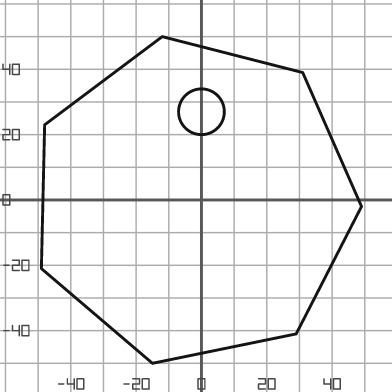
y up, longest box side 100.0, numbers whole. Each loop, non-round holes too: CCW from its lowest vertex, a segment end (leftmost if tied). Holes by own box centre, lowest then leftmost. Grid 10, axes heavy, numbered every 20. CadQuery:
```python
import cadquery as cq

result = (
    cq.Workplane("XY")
    .moveTo(-15.0, -50.0)
    .lineTo(29.0, -41.0)
    .lineTo(49.0, -2.0)
    .lineTo(31.0, 39.0)
    .lineTo(-12.0, 50.0)
    .lineTo(-48.0, 23.0)
    .lineTo(-49.0, -21.0)
    .close()
    .moveTo(0.0, 27.0)
    .circle(7.0)
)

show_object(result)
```